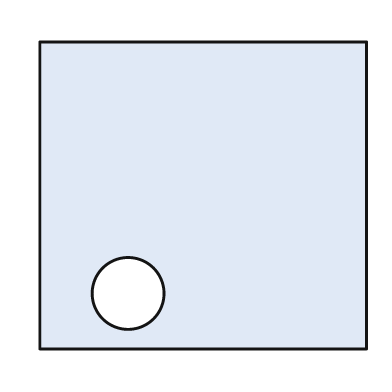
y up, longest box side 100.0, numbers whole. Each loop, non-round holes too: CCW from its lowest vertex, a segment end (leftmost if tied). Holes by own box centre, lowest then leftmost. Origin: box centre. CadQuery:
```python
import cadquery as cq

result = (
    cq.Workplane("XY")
    .moveTo(-50.0, -47.0)
    .lineTo(50.0, -47.0)
    .lineTo(50.0, 47.0)
    .lineTo(-50.0, 47.0)
    .close()
    .moveTo(-23.0, -30.0)
    .circle(11.0)
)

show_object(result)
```